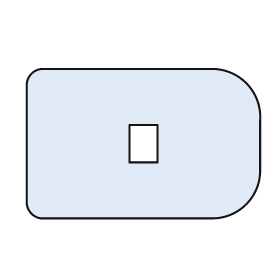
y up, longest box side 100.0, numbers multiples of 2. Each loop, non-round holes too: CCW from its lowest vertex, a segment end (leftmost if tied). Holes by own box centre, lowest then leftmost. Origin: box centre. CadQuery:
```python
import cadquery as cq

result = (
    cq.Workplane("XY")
    .moveTo(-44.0, -32.0)
    .lineTo(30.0, -32.0)
    .threePointArc((44.0, -26.0), (50.0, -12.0))
    .lineTo(50.0, 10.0)
    .threePointArc((44.0, 26.0), (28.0, 32.0))
    .lineTo(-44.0, 32.0)
    .threePointArc((-48.0, 30.0), (-50.0, 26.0))
    .lineTo(-50.0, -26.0)
    .threePointArc((-48.0, -30.0), (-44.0, -32.0))
    .close()
    .moveTo(-6.0, -8.0)
    .lineTo(6.0, -8.0)
    .lineTo(6.0, 8.0)
    .lineTo(-6.0, 8.0)
    .close()
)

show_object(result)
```